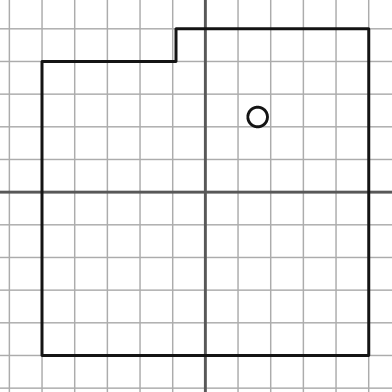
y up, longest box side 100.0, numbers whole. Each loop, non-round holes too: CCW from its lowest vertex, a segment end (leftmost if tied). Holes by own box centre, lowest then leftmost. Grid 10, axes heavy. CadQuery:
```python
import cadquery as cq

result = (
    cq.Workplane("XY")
    .moveTo(-50.0, -50.0)
    .lineTo(50.0, -50.0)
    .lineTo(50.0, 50.0)
    .lineTo(-9.0, 50.0)
    .lineTo(-9.0, 40.0)
    .lineTo(-50.0, 40.0)
    .close()
    .moveTo(16.0, 23.0)
    .circle(3.0)
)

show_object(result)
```